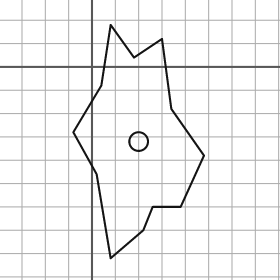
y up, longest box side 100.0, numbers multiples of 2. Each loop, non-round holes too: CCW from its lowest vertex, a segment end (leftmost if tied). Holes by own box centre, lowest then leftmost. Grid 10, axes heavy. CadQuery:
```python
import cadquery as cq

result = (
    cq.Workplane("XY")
    .moveTo(8.0, -82.0)
    .lineTo(22.0, -70.0)
    .lineTo(26.0, -60.0)
    .lineTo(38.0, -60.0)
    .lineTo(48.0, -38.0)
    .lineTo(34.0, -18.0)
    .lineTo(30.0, 12.0)
    .lineTo(18.0, 4.0)
    .lineTo(8.0, 18.0)
    .lineTo(4.0, -8.0)
    .lineTo(-8.0, -28.0)
    .lineTo(2.0, -46.0)
    .close()
    .moveTo(20.0, -32.0)
    .circle(4.0)
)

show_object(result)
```